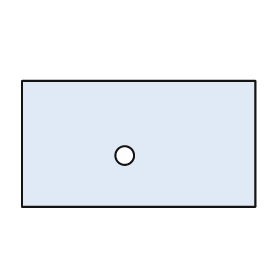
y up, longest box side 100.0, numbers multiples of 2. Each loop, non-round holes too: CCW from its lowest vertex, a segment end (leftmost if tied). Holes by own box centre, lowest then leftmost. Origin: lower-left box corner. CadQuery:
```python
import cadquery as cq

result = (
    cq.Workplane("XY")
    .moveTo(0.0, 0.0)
    .lineTo(100.0, 0.0)
    .lineTo(100.0, 54.0)
    .lineTo(0.0, 54.0)
    .close()
    .moveTo(44.0, 22.0)
    .circle(4.0)
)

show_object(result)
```